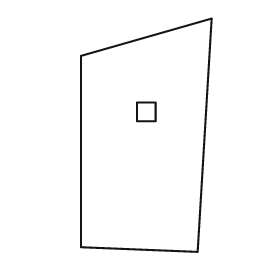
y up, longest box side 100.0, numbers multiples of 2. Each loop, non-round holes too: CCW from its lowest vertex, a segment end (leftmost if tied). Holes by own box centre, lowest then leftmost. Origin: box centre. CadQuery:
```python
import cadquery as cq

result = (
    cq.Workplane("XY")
    .moveTo(22.0, -50.0)
    .lineTo(28.0, 50.0)
    .lineTo(-28.0, 34.0)
    .lineTo(-28.0, -48.0)
    .close()
    .moveTo(-4.0, 6.0)
    .lineTo(4.0, 6.0)
    .lineTo(4.0, 14.0)
    .lineTo(-4.0, 14.0)
    .close()
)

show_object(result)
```